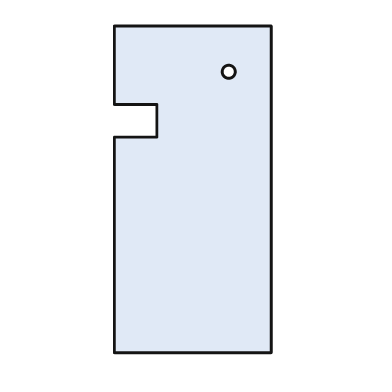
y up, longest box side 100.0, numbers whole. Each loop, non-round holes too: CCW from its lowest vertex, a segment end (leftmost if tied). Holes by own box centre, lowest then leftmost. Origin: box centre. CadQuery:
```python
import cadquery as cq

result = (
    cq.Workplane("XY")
    .moveTo(-24.0, -50.0)
    .lineTo(24.0, -50.0)
    .lineTo(24.0, 50.0)
    .lineTo(-24.0, 50.0)
    .lineTo(-24.0, 26.0)
    .lineTo(-11.0, 26.0)
    .lineTo(-11.0, 16.0)
    .lineTo(-24.0, 16.0)
    .close()
    .moveTo(11.0, 36.0)
    .circle(2.0)
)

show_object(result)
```